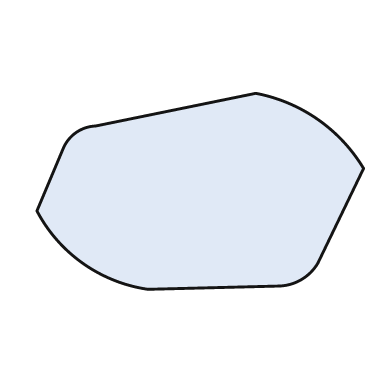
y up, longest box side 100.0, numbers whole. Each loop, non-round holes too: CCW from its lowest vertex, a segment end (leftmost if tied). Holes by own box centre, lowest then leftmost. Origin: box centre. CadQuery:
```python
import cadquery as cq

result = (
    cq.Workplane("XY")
    .moveTo(-16.0, -30.0)
    .lineTo(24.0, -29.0)
    .threePointArc((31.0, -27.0), (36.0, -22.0))
    .lineTo(50.0, 7.0)
    .threePointArc((36.0, 22.0), (17.0, 30.0))
    .lineTo(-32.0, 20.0)
    .threePointArc((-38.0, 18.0), (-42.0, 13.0))
    .lineTo(-50.0, -6.0)
    .threePointArc((-36.0, -22.0), (-16.0, -30.0))
    .close()
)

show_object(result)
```